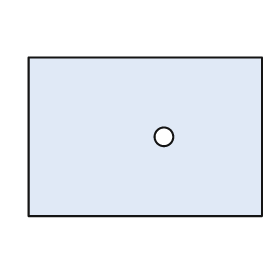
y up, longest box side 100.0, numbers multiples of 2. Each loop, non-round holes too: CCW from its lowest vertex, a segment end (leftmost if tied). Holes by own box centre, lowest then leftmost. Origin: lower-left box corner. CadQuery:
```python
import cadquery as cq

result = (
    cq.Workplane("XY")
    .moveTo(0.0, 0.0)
    .lineTo(100.0, 0.0)
    .lineTo(100.0, 68.0)
    .lineTo(0.0, 68.0)
    .close()
    .moveTo(58.0, 34.0)
    .circle(4.0)
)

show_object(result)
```